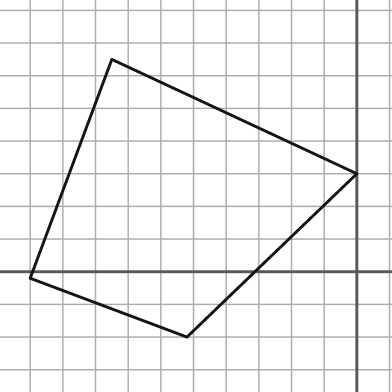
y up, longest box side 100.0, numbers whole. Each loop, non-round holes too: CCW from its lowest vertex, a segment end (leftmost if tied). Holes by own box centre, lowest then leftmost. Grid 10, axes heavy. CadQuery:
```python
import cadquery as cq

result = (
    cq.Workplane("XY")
    .moveTo(-52.0, -20.0)
    .lineTo(0.0, 30.0)
    .lineTo(-75.0, 65.0)
    .lineTo(-100.0, -2.0)
    .close()
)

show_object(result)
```